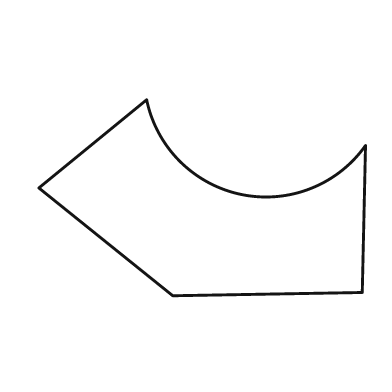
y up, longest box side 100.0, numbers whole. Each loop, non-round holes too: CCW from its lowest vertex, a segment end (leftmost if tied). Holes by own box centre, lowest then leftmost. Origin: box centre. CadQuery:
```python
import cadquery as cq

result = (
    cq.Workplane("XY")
    .moveTo(-9.0, -30.0)
    .lineTo(49.0, -29.0)
    .lineTo(50.0, 16.0)
    .threePointArc((12.0, 1.0), (-17.0, 30.0))
    .lineTo(-50.0, 3.0)
    .close()
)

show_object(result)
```